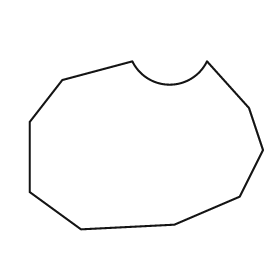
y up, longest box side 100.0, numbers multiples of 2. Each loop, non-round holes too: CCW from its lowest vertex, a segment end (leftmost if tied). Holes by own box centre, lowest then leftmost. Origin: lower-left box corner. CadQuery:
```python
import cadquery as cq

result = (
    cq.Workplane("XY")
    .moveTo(22.0, 0.0)
    .lineTo(62.0, 2.0)
    .lineTo(90.0, 14.0)
    .lineTo(100.0, 34.0)
    .lineTo(94.0, 52.0)
    .lineTo(76.0, 72.0)
    .threePointArc((60.0, 62.0), (44.0, 72.0))
    .lineTo(14.0, 64.0)
    .lineTo(0.0, 46.0)
    .lineTo(0.0, 16.0)
    .close()
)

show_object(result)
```